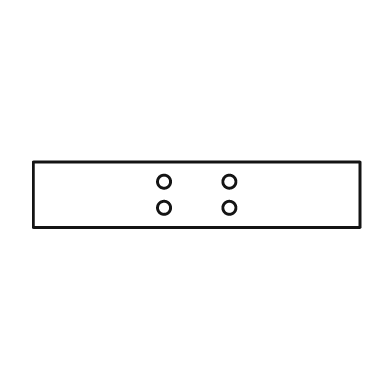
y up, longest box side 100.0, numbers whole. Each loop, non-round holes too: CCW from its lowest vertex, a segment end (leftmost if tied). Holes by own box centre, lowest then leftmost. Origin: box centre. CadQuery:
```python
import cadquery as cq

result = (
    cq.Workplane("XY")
    .moveTo(-50.0, -10.0)
    .lineTo(50.0, -10.0)
    .lineTo(50.0, 10.0)
    .lineTo(-50.0, 10.0)
    .close()
    .moveTo(-10.0, -4.0)
    .circle(2.0)
    .moveTo(10.0, -4.0)
    .circle(2.0)
    .moveTo(-10.0, 4.0)
    .circle(2.0)
    .moveTo(10.0, 4.0)
    .circle(2.0)
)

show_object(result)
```